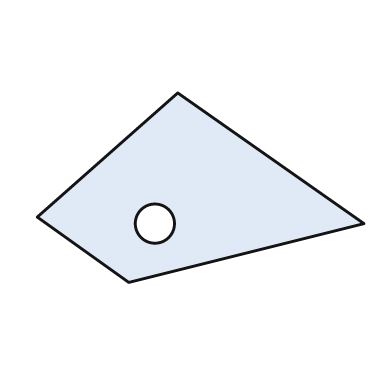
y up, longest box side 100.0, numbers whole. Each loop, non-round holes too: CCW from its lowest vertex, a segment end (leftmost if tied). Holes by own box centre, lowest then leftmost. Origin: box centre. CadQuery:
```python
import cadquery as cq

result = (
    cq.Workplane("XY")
    .moveTo(-22.0, -29.0)
    .lineTo(50.0, -11.0)
    .lineTo(-7.0, 29.0)
    .lineTo(-50.0, -9.0)
    .close()
    .moveTo(-14.0, -11.0)
    .circle(6.0)
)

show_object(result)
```